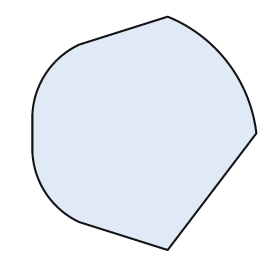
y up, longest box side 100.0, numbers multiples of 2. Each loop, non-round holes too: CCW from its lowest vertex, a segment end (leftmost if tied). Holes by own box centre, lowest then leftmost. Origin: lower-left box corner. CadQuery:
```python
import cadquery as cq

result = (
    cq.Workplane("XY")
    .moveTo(58.0, 0.0)
    .lineTo(96.0, 50.0)
    .threePointArc((84.0, 80.0), (58.0, 100.0))
    .lineTo(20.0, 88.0)
    .threePointArc((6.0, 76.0), (0.0, 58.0))
    .lineTo(0.0, 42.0)
    .threePointArc((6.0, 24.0), (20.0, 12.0))
    .close()
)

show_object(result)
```